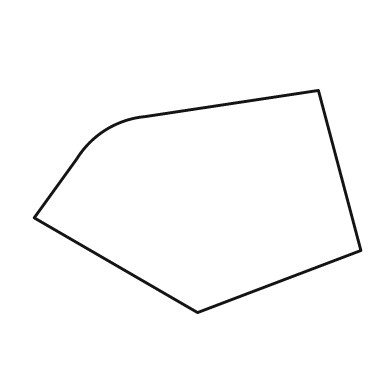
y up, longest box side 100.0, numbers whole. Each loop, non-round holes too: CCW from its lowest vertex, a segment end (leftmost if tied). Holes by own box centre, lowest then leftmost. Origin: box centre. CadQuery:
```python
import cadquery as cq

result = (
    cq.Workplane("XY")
    .moveTo(0.0, -34.0)
    .lineTo(50.0, -15.0)
    .lineTo(37.0, 34.0)
    .lineTo(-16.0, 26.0)
    .threePointArc((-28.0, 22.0), (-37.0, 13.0))
    .lineTo(-50.0, -5.0)
    .close()
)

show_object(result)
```